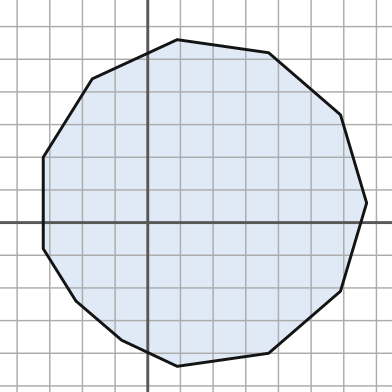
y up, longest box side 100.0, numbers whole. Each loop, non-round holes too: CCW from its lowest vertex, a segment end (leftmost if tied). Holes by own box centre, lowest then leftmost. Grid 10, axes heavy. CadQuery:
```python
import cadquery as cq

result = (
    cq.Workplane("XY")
    .moveTo(9.0, -44.0)
    .lineTo(37.0, -40.0)
    .lineTo(59.0, -21.0)
    .lineTo(67.0, 6.0)
    .lineTo(59.0, 33.0)
    .lineTo(37.0, 52.0)
    .lineTo(9.0, 56.0)
    .lineTo(-17.0, 44.0)
    .lineTo(-32.0, 20.0)
    .lineTo(-32.0, -8.0)
    .lineTo(-22.0, -24.0)
    .lineTo(-8.0, -36.0)
    .close()
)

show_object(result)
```